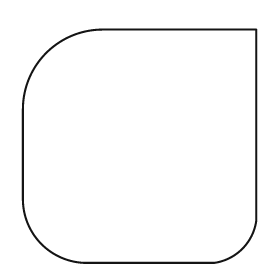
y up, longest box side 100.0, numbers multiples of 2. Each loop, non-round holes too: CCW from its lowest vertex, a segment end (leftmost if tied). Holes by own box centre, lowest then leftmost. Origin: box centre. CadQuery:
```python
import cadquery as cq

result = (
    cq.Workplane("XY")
    .moveTo(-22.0, -50.0)
    .lineTo(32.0, -50.0)
    .threePointArc((44.0, -44.0), (50.0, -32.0))
    .lineTo(50.0, 50.0)
    .lineTo(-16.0, 50.0)
    .threePointArc((-40.0, 40.0), (-50.0, 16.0))
    .lineTo(-50.0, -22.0)
    .threePointArc((-42.0, -42.0), (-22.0, -50.0))
    .close()
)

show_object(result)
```